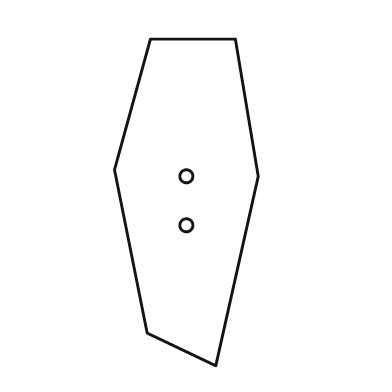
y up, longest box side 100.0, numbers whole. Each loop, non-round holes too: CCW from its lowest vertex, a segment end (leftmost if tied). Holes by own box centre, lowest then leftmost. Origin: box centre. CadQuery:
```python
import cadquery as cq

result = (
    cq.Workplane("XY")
    .moveTo(9.0, -50.0)
    .lineTo(22.0, 8.0)
    .lineTo(15.0, 50.0)
    .lineTo(-11.0, 50.0)
    .lineTo(-22.0, 10.0)
    .lineTo(-12.0, -40.0)
    .close()
    .moveTo(0.0, -7.0)
    .circle(2.0)
    .moveTo(0.0, 8.0)
    .circle(2.0)
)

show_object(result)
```